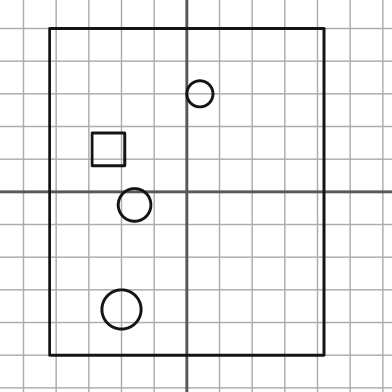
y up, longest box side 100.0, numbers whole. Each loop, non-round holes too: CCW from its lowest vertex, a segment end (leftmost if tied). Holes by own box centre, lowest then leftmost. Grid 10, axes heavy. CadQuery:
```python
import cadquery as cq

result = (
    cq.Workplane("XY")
    .moveTo(-42.0, -50.0)
    .lineTo(42.0, -50.0)
    .lineTo(42.0, 50.0)
    .lineTo(-42.0, 50.0)
    .close()
    .moveTo(-20.0, -36.0)
    .circle(6.0)
    .moveTo(-16.0, -4.0)
    .circle(5.0)
    .moveTo(-29.0, 8.0)
    .lineTo(-19.0, 8.0)
    .lineTo(-19.0, 18.0)
    .lineTo(-29.0, 18.0)
    .close()
    .moveTo(4.0, 30.0)
    .circle(4.0)
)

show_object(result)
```